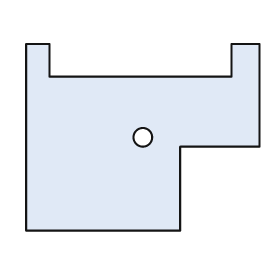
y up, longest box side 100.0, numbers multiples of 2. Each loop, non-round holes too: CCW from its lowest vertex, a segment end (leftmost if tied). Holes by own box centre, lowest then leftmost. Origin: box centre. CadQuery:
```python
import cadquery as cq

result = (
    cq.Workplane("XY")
    .moveTo(-50.0, -40.0)
    .lineTo(16.0, -40.0)
    .lineTo(16.0, -4.0)
    .lineTo(50.0, -4.0)
    .lineTo(50.0, 40.0)
    .lineTo(38.0, 40.0)
    .lineTo(38.0, 26.0)
    .lineTo(-40.0, 26.0)
    .lineTo(-40.0, 40.0)
    .lineTo(-50.0, 40.0)
    .close()
    .moveTo(0.0, 0.0)
    .circle(4.0)
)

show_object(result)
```